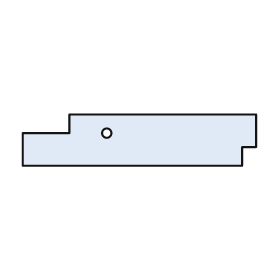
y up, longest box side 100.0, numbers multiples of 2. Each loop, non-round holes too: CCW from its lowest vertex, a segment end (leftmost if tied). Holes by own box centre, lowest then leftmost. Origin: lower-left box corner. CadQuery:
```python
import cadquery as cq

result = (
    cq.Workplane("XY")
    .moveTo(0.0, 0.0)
    .lineTo(94.0, 0.0)
    .lineTo(94.0, 8.0)
    .lineTo(100.0, 8.0)
    .lineTo(100.0, 22.0)
    .lineTo(20.0, 22.0)
    .lineTo(20.0, 14.0)
    .lineTo(0.0, 14.0)
    .close()
    .moveTo(36.0, 14.0)
    .circle(2.0)
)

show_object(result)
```